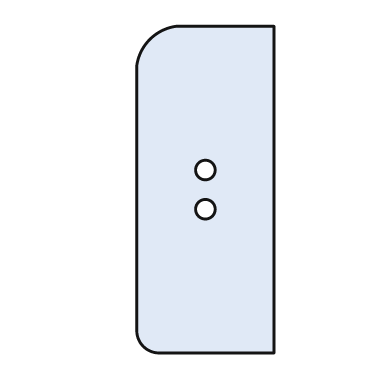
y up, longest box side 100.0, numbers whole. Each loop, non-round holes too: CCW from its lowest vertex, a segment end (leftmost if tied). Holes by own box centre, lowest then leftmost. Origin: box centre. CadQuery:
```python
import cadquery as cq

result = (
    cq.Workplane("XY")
    .moveTo(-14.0, -50.0)
    .lineTo(21.0, -50.0)
    .lineTo(21.0, 50.0)
    .lineTo(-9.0, 50.0)
    .threePointArc((-17.0, 46.0), (-21.0, 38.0))
    .lineTo(-21.0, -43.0)
    .threePointArc((-19.0, -48.0), (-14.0, -50.0))
    .close()
    .moveTo(0.0, -6.0)
    .circle(3.0)
    .moveTo(0.0, 6.0)
    .circle(3.0)
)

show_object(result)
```